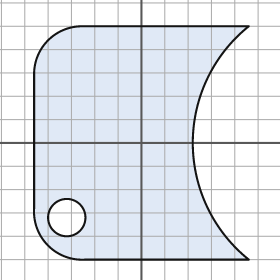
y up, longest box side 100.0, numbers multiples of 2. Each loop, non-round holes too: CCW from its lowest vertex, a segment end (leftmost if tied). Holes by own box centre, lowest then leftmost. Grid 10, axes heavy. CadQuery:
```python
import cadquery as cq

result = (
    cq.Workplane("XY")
    .moveTo(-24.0, -50.0)
    .lineTo(46.0, -50.0)
    .threePointArc((22.0, 0.0), (46.0, 50.0))
    .lineTo(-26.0, 50.0)
    .threePointArc((-40.0, 44.0), (-46.0, 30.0))
    .lineTo(-46.0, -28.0)
    .threePointArc((-40.0, -44.0), (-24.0, -50.0))
    .close()
    .moveTo(-32.0, -32.0)
    .circle(8.0)
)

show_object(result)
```